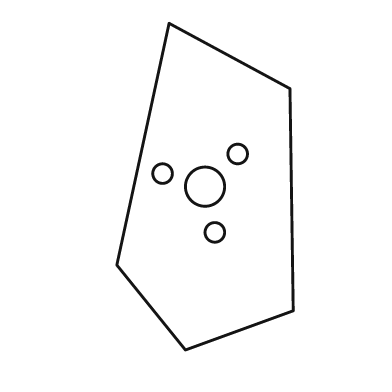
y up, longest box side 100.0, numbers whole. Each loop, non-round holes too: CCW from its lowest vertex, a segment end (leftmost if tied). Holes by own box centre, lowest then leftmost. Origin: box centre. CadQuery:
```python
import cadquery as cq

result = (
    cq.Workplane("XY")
    .moveTo(-6.0, -50.0)
    .lineTo(27.0, -38.0)
    .lineTo(26.0, 30.0)
    .lineTo(-11.0, 50.0)
    .lineTo(-27.0, -24.0)
    .close()
    .moveTo(3.0, -14.0)
    .circle(3.0)
    .moveTo(0.0, 0.0)
    .circle(6.0)
    .moveTo(-13.0, 4.0)
    .circle(3.0)
    .moveTo(10.0, 10.0)
    .circle(3.0)
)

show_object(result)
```